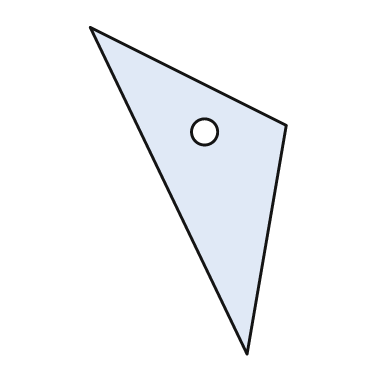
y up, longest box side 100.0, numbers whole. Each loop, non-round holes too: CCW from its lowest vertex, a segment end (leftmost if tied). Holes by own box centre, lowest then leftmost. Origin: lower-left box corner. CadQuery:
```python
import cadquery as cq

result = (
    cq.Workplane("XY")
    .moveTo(48.0, 0.0)
    .lineTo(60.0, 70.0)
    .lineTo(0.0, 100.0)
    .close()
    .moveTo(35.0, 68.0)
    .circle(4.0)
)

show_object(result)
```